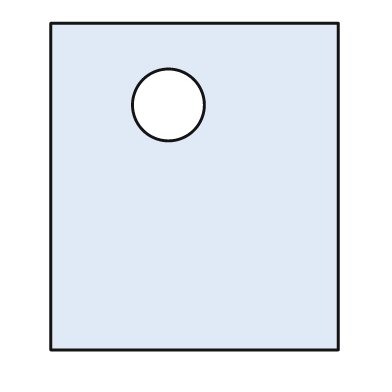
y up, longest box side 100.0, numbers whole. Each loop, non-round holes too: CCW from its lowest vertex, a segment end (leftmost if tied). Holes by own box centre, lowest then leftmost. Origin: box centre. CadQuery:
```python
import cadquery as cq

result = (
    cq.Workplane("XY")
    .moveTo(-44.0, -50.0)
    .lineTo(44.0, -50.0)
    .lineTo(44.0, 50.0)
    .lineTo(-44.0, 50.0)
    .close()
    .moveTo(-8.0, 25.0)
    .circle(11.0)
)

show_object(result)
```